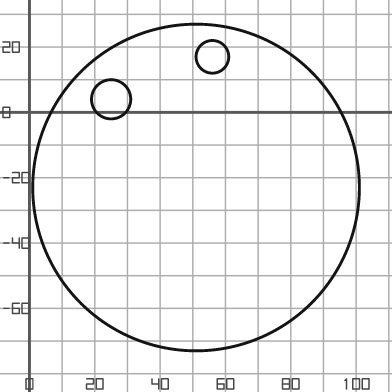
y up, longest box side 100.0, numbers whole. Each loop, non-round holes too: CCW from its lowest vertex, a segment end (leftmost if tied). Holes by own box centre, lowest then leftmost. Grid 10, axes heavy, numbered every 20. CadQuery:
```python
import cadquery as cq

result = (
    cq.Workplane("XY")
    .moveTo(51.0, -23.0)
    .circle(50.0)
    .moveTo(25.0, 4.0)
    .circle(6.0)
    .moveTo(56.0, 17.0)
    .circle(5.0)
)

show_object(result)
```